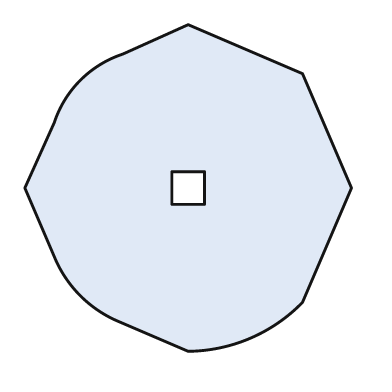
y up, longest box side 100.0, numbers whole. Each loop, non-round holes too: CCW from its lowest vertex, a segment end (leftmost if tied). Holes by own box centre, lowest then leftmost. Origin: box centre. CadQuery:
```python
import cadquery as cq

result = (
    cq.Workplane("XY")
    .moveTo(0.0, -50.0)
    .threePointArc((19.0, -46.0), (35.0, -35.0))
    .lineTo(50.0, 0.0)
    .lineTo(35.0, 35.0)
    .lineTo(0.0, 50.0)
    .lineTo(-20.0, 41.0)
    .threePointArc((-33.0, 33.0), (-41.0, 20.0))
    .lineTo(-50.0, 0.0)
    .lineTo(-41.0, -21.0)
    .threePointArc((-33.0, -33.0), (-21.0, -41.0))
    .close()
    .moveTo(-5.0, -5.0)
    .lineTo(5.0, -5.0)
    .lineTo(5.0, 5.0)
    .lineTo(-5.0, 5.0)
    .close()
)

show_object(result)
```